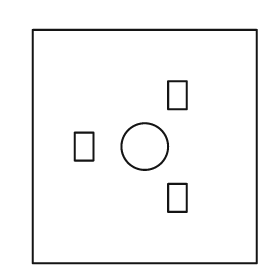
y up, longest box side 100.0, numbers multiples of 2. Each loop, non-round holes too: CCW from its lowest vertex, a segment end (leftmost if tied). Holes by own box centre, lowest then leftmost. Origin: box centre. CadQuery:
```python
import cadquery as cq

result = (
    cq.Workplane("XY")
    .moveTo(-48.0, -50.0)
    .lineTo(48.0, -50.0)
    .lineTo(48.0, 50.0)
    .lineTo(-48.0, 50.0)
    .close()
    .moveTo(10.0, -28.0)
    .lineTo(18.0, -28.0)
    .lineTo(18.0, -16.0)
    .lineTo(10.0, -16.0)
    .close()
    .moveTo(-30.0, -6.0)
    .lineTo(-22.0, -6.0)
    .lineTo(-22.0, 6.0)
    .lineTo(-30.0, 6.0)
    .close()
    .moveTo(0.0, 0.0)
    .circle(10.0)
    .moveTo(10.0, 16.0)
    .lineTo(18.0, 16.0)
    .lineTo(18.0, 28.0)
    .lineTo(10.0, 28.0)
    .close()
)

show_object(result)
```